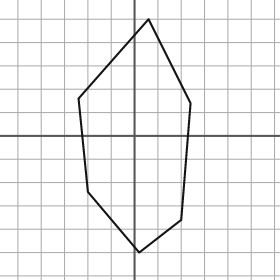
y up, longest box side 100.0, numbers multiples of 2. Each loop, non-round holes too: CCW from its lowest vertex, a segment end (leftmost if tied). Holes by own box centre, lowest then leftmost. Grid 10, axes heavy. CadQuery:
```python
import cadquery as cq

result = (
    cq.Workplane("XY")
    .moveTo(2.0, -50.0)
    .lineTo(20.0, -36.0)
    .lineTo(24.0, 14.0)
    .lineTo(6.0, 50.0)
    .lineTo(-24.0, 16.0)
    .lineTo(-20.0, -24.0)
    .close()
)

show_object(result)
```